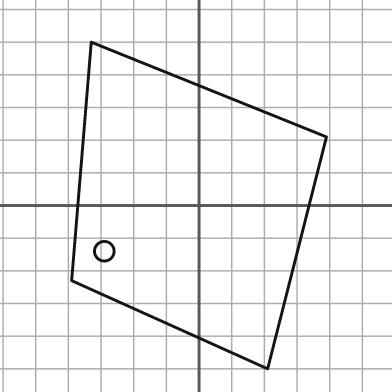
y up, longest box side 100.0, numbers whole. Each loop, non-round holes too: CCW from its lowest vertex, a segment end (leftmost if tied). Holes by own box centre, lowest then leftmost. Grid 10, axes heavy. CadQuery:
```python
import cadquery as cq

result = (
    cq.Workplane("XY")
    .moveTo(21.0, -50.0)
    .lineTo(39.0, 21.0)
    .lineTo(-33.0, 50.0)
    .lineTo(-39.0, -23.0)
    .close()
    .moveTo(-29.0, -14.0)
    .circle(3.0)
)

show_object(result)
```